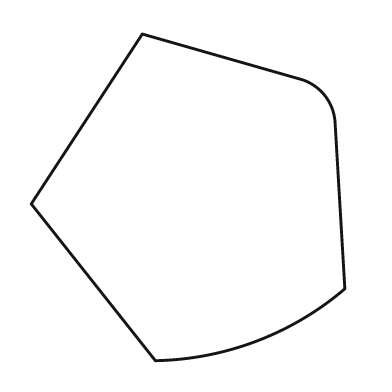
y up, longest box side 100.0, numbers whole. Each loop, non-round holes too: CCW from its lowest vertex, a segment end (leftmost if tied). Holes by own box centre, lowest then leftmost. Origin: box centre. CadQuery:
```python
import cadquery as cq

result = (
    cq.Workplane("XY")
    .moveTo(-10.0, -50.0)
    .threePointArc((21.0, -44.0), (48.0, -28.0))
    .lineTo(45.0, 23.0)
    .threePointArc((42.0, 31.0), (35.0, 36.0))
    .lineTo(-14.0, 50.0)
    .lineTo(-48.0, -2.0)
    .close()
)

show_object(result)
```